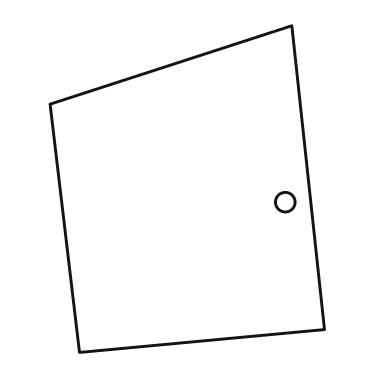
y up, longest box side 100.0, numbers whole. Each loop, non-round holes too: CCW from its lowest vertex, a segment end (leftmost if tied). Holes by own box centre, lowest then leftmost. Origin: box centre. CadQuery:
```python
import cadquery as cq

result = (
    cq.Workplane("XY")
    .moveTo(-33.0, -50.0)
    .lineTo(42.0, -43.0)
    .lineTo(32.0, 50.0)
    .lineTo(-42.0, 26.0)
    .close()
    .moveTo(30.0, -4.0)
    .circle(3.0)
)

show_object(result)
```